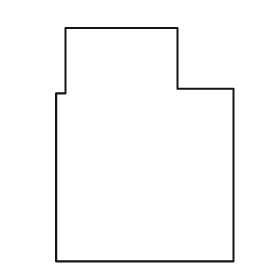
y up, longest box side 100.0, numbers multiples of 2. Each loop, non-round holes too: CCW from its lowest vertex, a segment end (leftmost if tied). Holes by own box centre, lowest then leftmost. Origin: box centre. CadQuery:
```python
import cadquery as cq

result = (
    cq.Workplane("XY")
    .moveTo(-38.0, -50.0)
    .lineTo(38.0, -50.0)
    .lineTo(38.0, 24.0)
    .lineTo(14.0, 24.0)
    .lineTo(14.0, 50.0)
    .lineTo(-34.0, 50.0)
    .lineTo(-34.0, 22.0)
    .lineTo(-38.0, 22.0)
    .close()
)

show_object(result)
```